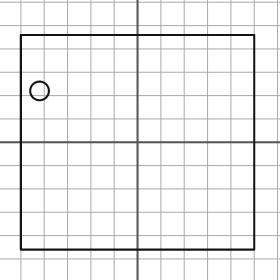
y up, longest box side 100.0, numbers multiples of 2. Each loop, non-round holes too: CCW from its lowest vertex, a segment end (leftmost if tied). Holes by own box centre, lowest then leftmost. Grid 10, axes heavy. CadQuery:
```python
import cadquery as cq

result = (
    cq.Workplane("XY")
    .moveTo(-50.0, -46.0)
    .lineTo(50.0, -46.0)
    .lineTo(50.0, 46.0)
    .lineTo(-50.0, 46.0)
    .close()
    .moveTo(-42.0, 22.0)
    .circle(4.0)
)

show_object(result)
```